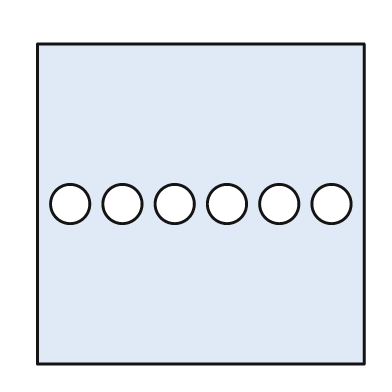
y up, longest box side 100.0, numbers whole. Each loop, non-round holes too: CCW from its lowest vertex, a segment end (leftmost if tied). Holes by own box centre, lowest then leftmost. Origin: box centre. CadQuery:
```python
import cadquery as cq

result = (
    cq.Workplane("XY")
    .moveTo(-50.0, -49.0)
    .lineTo(50.0, -49.0)
    .lineTo(50.0, 49.0)
    .lineTo(-50.0, 49.0)
    .close()
    .moveTo(-40.0, 0.0)
    .circle(6.0)
    .moveTo(-24.0, 0.0)
    .circle(6.0)
    .moveTo(-8.0, 0.0)
    .circle(6.0)
    .moveTo(8.0, 0.0)
    .circle(6.0)
    .moveTo(24.0, 0.0)
    .circle(6.0)
    .moveTo(40.0, 0.0)
    .circle(6.0)
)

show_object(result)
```